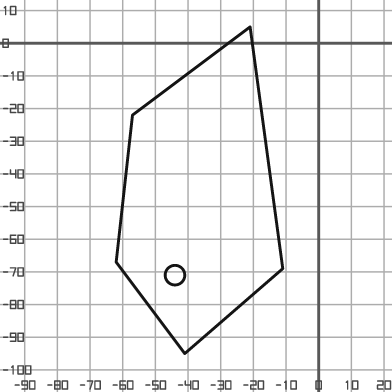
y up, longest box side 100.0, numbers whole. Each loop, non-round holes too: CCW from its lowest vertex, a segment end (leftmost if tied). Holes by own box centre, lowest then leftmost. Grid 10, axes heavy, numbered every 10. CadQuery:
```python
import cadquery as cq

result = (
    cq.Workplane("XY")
    .moveTo(-41.0, -95.0)
    .lineTo(-11.0, -69.0)
    .lineTo(-21.0, 5.0)
    .lineTo(-57.0, -22.0)
    .lineTo(-62.0, -67.0)
    .close()
    .moveTo(-44.0, -71.0)
    .circle(3.0)
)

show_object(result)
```